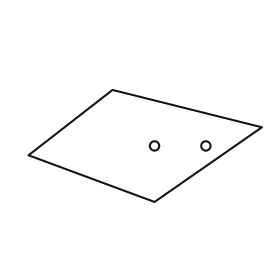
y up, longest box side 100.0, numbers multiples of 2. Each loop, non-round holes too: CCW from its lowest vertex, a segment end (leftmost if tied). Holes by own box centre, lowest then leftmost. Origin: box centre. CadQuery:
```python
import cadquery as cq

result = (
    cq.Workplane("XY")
    .moveTo(4.0, -24.0)
    .lineTo(50.0, 8.0)
    .lineTo(-14.0, 24.0)
    .lineTo(-50.0, -4.0)
    .close()
    .moveTo(4.0, 0.0)
    .circle(2.0)
    .moveTo(26.0, 0.0)
    .circle(2.0)
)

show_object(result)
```